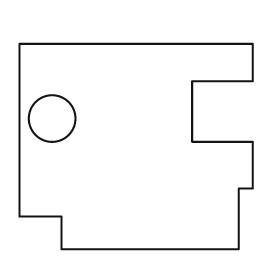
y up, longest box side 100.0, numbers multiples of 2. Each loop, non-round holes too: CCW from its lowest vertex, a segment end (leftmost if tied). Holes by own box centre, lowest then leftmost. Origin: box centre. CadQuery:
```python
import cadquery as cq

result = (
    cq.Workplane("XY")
    .moveTo(-32.0, -44.0)
    .lineTo(44.0, -44.0)
    .lineTo(44.0, -18.0)
    .lineTo(50.0, -18.0)
    .lineTo(50.0, 2.0)
    .lineTo(24.0, 2.0)
    .lineTo(24.0, 28.0)
    .lineTo(50.0, 28.0)
    .lineTo(50.0, 44.0)
    .lineTo(-50.0, 44.0)
    .lineTo(-50.0, -30.0)
    .lineTo(-32.0, -30.0)
    .close()
    .moveTo(-36.0, 12.0)
    .circle(10.0)
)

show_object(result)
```